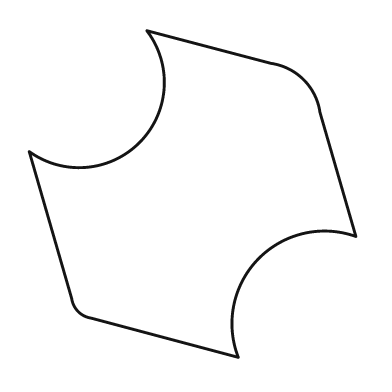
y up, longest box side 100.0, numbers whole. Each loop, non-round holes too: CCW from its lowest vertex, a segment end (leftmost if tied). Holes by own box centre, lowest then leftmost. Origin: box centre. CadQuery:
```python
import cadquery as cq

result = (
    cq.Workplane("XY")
    .moveTo(14.0, -50.0)
    .threePointArc((20.0, -20.0), (50.0, -13.0))
    .lineTo(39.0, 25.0)
    .threePointArc((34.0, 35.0), (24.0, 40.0))
    .lineTo(-14.0, 50.0)
    .threePointArc((-16.0, 16.0), (-50.0, 13.0))
    .lineTo(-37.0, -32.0)
    .threePointArc((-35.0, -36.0), (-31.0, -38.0))
    .close()
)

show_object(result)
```